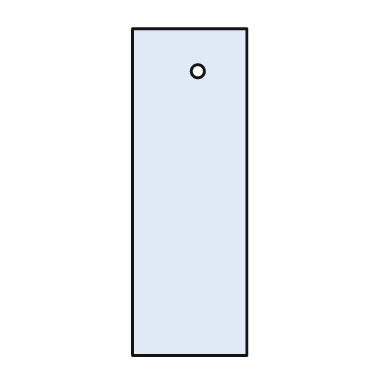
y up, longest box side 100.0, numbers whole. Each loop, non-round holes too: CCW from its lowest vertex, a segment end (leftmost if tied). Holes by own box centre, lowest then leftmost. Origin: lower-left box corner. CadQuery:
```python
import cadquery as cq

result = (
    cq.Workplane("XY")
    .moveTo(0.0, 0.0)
    .lineTo(35.0, 0.0)
    .lineTo(35.0, 100.0)
    .lineTo(0.0, 100.0)
    .close()
    .moveTo(20.0, 87.0)
    .circle(2.0)
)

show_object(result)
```